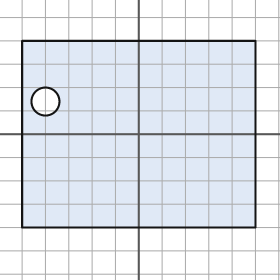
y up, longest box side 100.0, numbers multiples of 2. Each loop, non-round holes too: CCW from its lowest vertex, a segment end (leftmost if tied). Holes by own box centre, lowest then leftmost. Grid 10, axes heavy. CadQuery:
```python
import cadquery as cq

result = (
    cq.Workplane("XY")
    .moveTo(-50.0, -40.0)
    .lineTo(50.0, -40.0)
    .lineTo(50.0, 40.0)
    .lineTo(-50.0, 40.0)
    .close()
    .moveTo(-40.0, 14.0)
    .circle(6.0)
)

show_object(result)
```